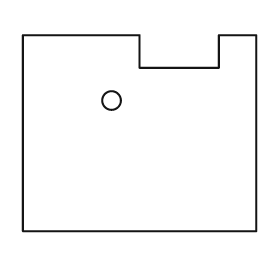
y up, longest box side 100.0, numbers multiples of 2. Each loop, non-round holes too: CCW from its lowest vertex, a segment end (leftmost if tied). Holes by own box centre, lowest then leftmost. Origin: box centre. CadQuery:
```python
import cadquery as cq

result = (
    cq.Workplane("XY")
    .moveTo(-50.0, -42.0)
    .lineTo(50.0, -42.0)
    .lineTo(50.0, 42.0)
    .lineTo(34.0, 42.0)
    .lineTo(34.0, 28.0)
    .lineTo(0.0, 28.0)
    .lineTo(0.0, 42.0)
    .lineTo(-50.0, 42.0)
    .close()
    .moveTo(-12.0, 14.0)
    .circle(4.0)
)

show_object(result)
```